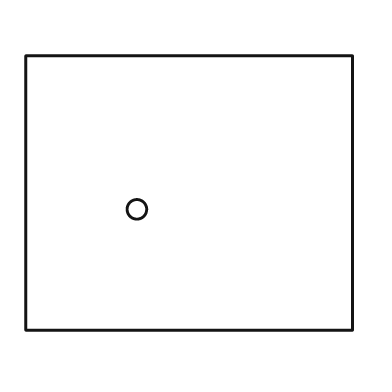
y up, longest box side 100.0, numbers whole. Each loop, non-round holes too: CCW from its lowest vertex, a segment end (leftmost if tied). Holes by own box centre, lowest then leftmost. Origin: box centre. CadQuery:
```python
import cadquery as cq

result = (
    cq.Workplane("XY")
    .moveTo(-50.0, -42.0)
    .lineTo(50.0, -42.0)
    .lineTo(50.0, 42.0)
    .lineTo(-50.0, 42.0)
    .close()
    .moveTo(-16.0, -5.0)
    .circle(3.0)
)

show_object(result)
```